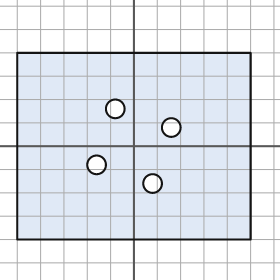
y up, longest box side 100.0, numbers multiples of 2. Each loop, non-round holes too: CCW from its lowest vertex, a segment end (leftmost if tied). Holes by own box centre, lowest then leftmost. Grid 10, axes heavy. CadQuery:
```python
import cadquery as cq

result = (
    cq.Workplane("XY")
    .moveTo(-50.0, -40.0)
    .lineTo(50.0, -40.0)
    .lineTo(50.0, 40.0)
    .lineTo(-50.0, 40.0)
    .close()
    .moveTo(8.0, -16.0)
    .circle(4.0)
    .moveTo(-16.0, -8.0)
    .circle(4.0)
    .moveTo(16.0, 8.0)
    .circle(4.0)
    .moveTo(-8.0, 16.0)
    .circle(4.0)
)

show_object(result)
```